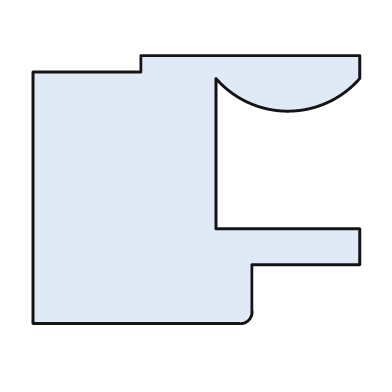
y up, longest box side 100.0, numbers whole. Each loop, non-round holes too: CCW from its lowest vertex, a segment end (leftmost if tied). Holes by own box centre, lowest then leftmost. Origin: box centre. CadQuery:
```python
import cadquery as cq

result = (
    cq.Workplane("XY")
    .moveTo(-50.0, -41.0)
    .lineTo(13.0, -41.0)
    .threePointArc((16.0, -40.0), (17.0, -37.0))
    .lineTo(17.0, -23.0)
    .lineTo(50.0, -23.0)
    .lineTo(50.0, -12.0)
    .lineTo(6.0, -12.0)
    .lineTo(6.0, 34.0)
    .threePointArc((28.0, 24.0), (50.0, 34.0))
    .lineTo(50.0, 41.0)
    .lineTo(-17.0, 41.0)
    .lineTo(-17.0, 36.0)
    .lineTo(-50.0, 36.0)
    .close()
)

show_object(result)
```